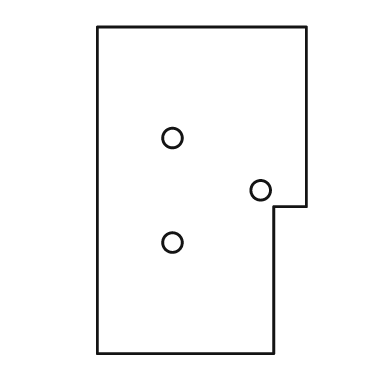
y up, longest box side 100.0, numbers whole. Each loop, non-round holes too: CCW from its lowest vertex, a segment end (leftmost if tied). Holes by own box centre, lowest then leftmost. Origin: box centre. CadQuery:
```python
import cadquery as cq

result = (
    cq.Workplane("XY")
    .moveTo(-32.0, -50.0)
    .lineTo(22.0, -50.0)
    .lineTo(22.0, -5.0)
    .lineTo(32.0, -5.0)
    .lineTo(32.0, 50.0)
    .lineTo(-32.0, 50.0)
    .close()
    .moveTo(-9.0, -16.0)
    .circle(3.0)
    .moveTo(18.0, 0.0)
    .circle(3.0)
    .moveTo(-9.0, 16.0)
    .circle(3.0)
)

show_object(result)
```